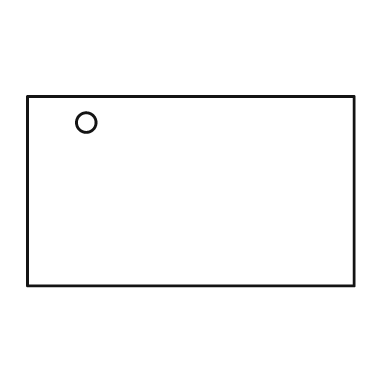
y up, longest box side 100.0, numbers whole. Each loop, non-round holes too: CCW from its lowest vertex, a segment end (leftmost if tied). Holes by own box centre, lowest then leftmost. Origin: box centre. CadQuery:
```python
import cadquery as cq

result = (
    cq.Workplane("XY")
    .moveTo(-50.0, -29.0)
    .lineTo(50.0, -29.0)
    .lineTo(50.0, 29.0)
    .lineTo(-50.0, 29.0)
    .close()
    .moveTo(-32.0, 21.0)
    .circle(3.0)
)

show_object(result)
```